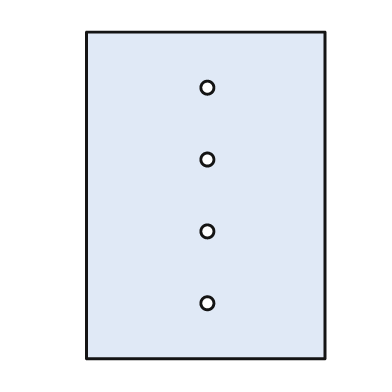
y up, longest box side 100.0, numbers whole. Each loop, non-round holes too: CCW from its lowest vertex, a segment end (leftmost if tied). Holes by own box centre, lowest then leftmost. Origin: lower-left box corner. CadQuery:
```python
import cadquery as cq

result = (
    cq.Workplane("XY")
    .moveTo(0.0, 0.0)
    .lineTo(73.0, 0.0)
    .lineTo(73.0, 100.0)
    .lineTo(0.0, 100.0)
    .close()
    .moveTo(37.0, 17.0)
    .circle(2.0)
    .moveTo(37.0, 39.0)
    .circle(2.0)
    .moveTo(37.0, 61.0)
    .circle(2.0)
    .moveTo(37.0, 83.0)
    .circle(2.0)
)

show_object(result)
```